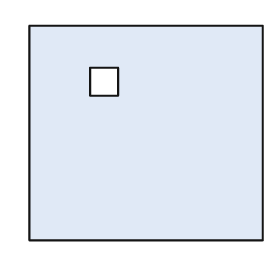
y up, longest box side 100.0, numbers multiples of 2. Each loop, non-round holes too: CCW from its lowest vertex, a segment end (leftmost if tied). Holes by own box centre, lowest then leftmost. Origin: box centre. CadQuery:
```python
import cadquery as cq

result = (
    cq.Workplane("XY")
    .moveTo(-50.0, -46.0)
    .lineTo(50.0, -46.0)
    .lineTo(50.0, 46.0)
    .lineTo(-50.0, 46.0)
    .close()
    .moveTo(-24.0, 16.0)
    .lineTo(-12.0, 16.0)
    .lineTo(-12.0, 28.0)
    .lineTo(-24.0, 28.0)
    .close()
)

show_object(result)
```